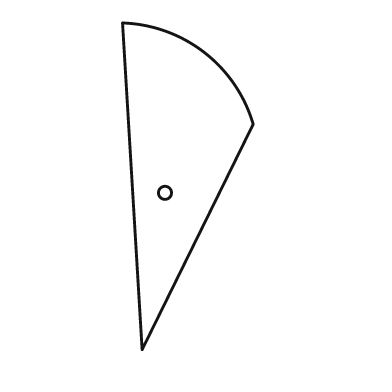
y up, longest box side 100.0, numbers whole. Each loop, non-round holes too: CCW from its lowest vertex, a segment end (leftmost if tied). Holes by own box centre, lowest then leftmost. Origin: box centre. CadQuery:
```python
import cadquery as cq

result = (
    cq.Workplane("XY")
    .moveTo(-14.0, -50.0)
    .lineTo(20.0, 19.0)
    .threePointArc((5.0, 41.0), (-20.0, 50.0))
    .close()
    .moveTo(-7.0, -2.0)
    .circle(2.0)
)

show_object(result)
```